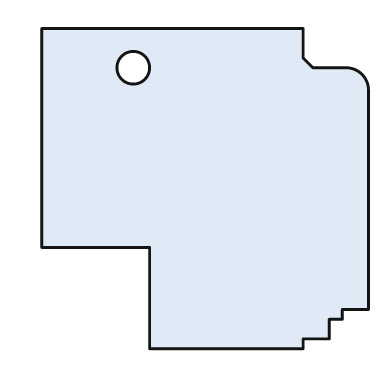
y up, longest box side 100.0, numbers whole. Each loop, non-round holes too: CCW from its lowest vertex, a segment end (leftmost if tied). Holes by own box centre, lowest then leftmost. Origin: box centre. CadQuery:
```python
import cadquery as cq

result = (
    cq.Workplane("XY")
    .moveTo(-17.0, -49.0)
    .lineTo(30.0, -49.0)
    .lineTo(30.0, -46.0)
    .lineTo(38.0, -46.0)
    .lineTo(38.0, -40.0)
    .lineTo(42.0, -40.0)
    .lineTo(42.0, -37.0)
    .lineTo(50.0, -37.0)
    .lineTo(50.0, 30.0)
    .threePointArc((48.0, 35.0), (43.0, 37.0))
    .lineTo(33.0, 37.0)
    .lineTo(30.0, 40.0)
    .lineTo(30.0, 49.0)
    .lineTo(-50.0, 49.0)
    .lineTo(-50.0, -18.0)
    .lineTo(-17.0, -18.0)
    .close()
    .moveTo(-22.0, 37.0)
    .circle(5.0)
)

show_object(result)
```